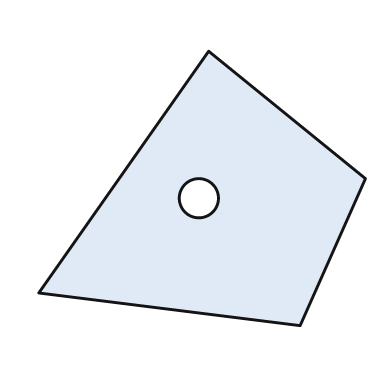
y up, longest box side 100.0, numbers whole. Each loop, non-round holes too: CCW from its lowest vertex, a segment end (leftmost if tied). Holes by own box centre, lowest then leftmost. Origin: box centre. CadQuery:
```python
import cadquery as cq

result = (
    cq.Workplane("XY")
    .moveTo(30.0, -42.0)
    .lineTo(50.0, 3.0)
    .lineTo(2.0, 42.0)
    .lineTo(-50.0, -32.0)
    .close()
    .moveTo(-1.0, -3.0)
    .circle(6.0)
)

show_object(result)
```